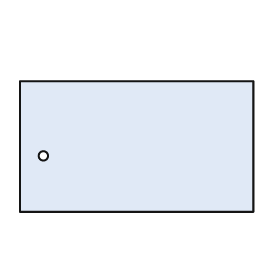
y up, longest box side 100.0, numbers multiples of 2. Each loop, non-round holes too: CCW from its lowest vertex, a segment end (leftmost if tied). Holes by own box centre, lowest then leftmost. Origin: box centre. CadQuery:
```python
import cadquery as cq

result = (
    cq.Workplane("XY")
    .moveTo(-50.0, -28.0)
    .lineTo(50.0, -28.0)
    .lineTo(50.0, 28.0)
    .lineTo(-50.0, 28.0)
    .close()
    .moveTo(-40.0, -4.0)
    .circle(2.0)
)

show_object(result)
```